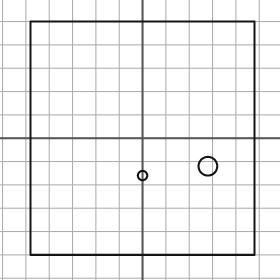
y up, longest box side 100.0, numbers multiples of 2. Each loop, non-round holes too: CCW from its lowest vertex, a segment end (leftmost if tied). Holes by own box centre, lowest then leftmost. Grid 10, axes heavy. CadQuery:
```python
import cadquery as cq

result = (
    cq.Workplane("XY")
    .moveTo(-48.0, -50.0)
    .lineTo(48.0, -50.0)
    .lineTo(48.0, 50.0)
    .lineTo(-48.0, 50.0)
    .close()
    .moveTo(0.0, -16.0)
    .circle(2.0)
    .moveTo(28.0, -12.0)
    .circle(4.0)
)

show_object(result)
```